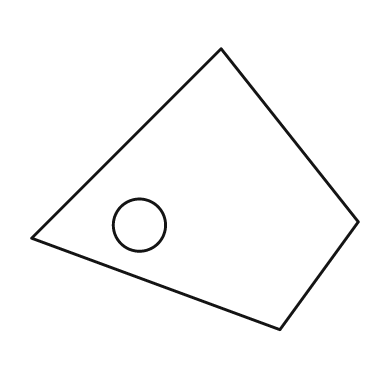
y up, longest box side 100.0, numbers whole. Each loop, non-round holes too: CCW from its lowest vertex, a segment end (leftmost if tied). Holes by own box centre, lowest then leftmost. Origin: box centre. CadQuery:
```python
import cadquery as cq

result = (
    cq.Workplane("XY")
    .moveTo(26.0, -43.0)
    .lineTo(50.0, -10.0)
    .lineTo(8.0, 43.0)
    .lineTo(-50.0, -15.0)
    .close()
    .moveTo(-17.0, -11.0)
    .circle(8.0)
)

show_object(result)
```